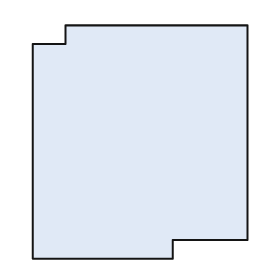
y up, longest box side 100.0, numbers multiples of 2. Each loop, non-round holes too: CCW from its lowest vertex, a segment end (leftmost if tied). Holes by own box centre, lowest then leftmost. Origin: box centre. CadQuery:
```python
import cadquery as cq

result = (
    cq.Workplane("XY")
    .moveTo(-46.0, -50.0)
    .lineTo(14.0, -50.0)
    .lineTo(14.0, -42.0)
    .lineTo(46.0, -42.0)
    .lineTo(46.0, 50.0)
    .lineTo(-32.0, 50.0)
    .lineTo(-32.0, 42.0)
    .lineTo(-46.0, 42.0)
    .close()
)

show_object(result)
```